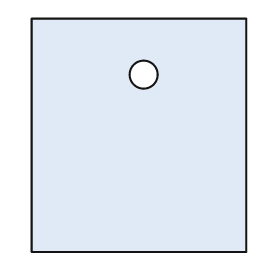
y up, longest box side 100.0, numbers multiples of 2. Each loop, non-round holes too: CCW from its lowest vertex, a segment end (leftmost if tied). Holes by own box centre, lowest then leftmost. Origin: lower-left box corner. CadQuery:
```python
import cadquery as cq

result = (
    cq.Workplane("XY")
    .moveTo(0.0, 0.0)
    .lineTo(92.0, 0.0)
    .lineTo(92.0, 100.0)
    .lineTo(0.0, 100.0)
    .close()
    .moveTo(48.0, 76.0)
    .circle(6.0)
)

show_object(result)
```